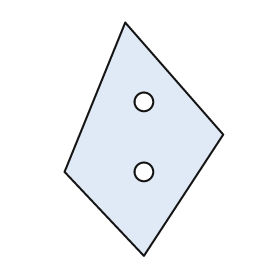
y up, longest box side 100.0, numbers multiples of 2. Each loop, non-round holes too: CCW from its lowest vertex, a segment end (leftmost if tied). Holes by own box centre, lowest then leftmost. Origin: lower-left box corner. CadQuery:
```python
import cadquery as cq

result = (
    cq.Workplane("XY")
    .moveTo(34.0, 0.0)
    .lineTo(68.0, 52.0)
    .lineTo(26.0, 100.0)
    .lineTo(0.0, 36.0)
    .close()
    .moveTo(34.0, 36.0)
    .circle(4.0)
    .moveTo(34.0, 66.0)
    .circle(4.0)
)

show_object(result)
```